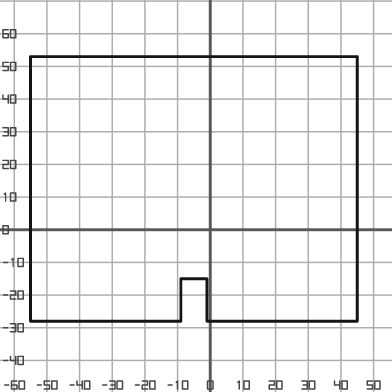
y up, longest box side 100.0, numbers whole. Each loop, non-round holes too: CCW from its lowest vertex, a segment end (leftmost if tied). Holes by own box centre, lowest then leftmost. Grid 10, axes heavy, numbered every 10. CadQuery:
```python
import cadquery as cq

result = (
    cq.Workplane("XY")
    .moveTo(-55.0, -28.0)
    .lineTo(-9.0, -28.0)
    .lineTo(-9.0, -15.0)
    .lineTo(-1.0, -15.0)
    .lineTo(-1.0, -28.0)
    .lineTo(45.0, -28.0)
    .lineTo(45.0, 53.0)
    .lineTo(-55.0, 53.0)
    .close()
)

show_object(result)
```